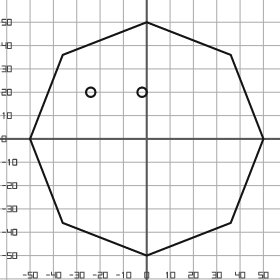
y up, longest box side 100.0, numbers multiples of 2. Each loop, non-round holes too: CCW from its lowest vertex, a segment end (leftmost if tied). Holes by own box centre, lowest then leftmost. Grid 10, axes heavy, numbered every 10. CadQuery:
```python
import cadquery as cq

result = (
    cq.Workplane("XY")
    .moveTo(0.0, -50.0)
    .lineTo(36.0, -36.0)
    .lineTo(50.0, 0.0)
    .lineTo(36.0, 36.0)
    .lineTo(0.0, 50.0)
    .lineTo(-36.0, 36.0)
    .lineTo(-50.0, 0.0)
    .lineTo(-36.0, -36.0)
    .close()
    .moveTo(-24.0, 20.0)
    .circle(2.0)
    .moveTo(-2.0, 20.0)
    .circle(2.0)
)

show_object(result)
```